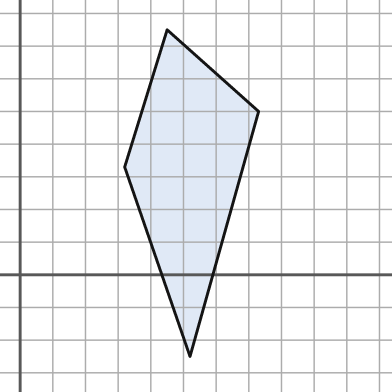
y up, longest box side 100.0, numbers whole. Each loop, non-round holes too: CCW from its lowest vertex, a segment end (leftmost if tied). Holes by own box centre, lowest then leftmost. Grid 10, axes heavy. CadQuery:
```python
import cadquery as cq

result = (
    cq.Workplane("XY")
    .moveTo(52.0, -25.0)
    .lineTo(73.0, 50.0)
    .lineTo(45.0, 75.0)
    .lineTo(32.0, 33.0)
    .close()
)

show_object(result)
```